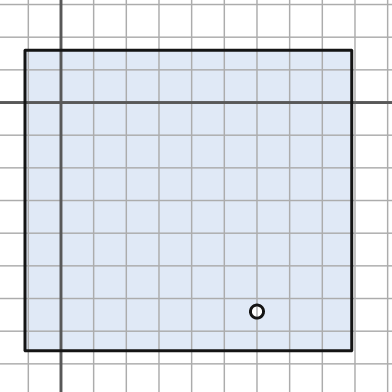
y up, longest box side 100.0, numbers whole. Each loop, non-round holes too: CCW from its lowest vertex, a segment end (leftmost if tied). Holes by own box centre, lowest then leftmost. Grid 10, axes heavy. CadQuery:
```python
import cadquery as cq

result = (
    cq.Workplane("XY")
    .moveTo(-11.0, -76.0)
    .lineTo(89.0, -76.0)
    .lineTo(89.0, 16.0)
    .lineTo(-11.0, 16.0)
    .close()
    .moveTo(60.0, -64.0)
    .circle(2.0)
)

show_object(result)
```